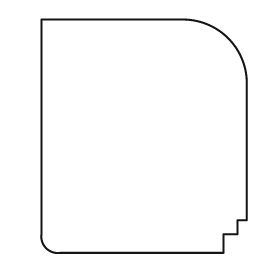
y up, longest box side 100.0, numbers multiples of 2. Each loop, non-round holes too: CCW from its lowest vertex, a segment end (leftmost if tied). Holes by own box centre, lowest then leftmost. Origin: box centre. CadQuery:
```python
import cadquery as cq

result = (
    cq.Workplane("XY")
    .moveTo(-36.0, -50.0)
    .lineTo(34.0, -50.0)
    .lineTo(34.0, -42.0)
    .lineTo(40.0, -42.0)
    .lineTo(40.0, -36.0)
    .lineTo(44.0, -36.0)
    .lineTo(44.0, 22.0)
    .threePointArc((36.0, 42.0), (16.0, 50.0))
    .lineTo(-44.0, 50.0)
    .lineTo(-44.0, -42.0)
    .threePointArc((-42.0, -48.0), (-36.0, -50.0))
    .close()
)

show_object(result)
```